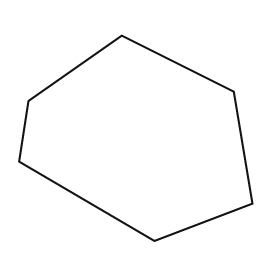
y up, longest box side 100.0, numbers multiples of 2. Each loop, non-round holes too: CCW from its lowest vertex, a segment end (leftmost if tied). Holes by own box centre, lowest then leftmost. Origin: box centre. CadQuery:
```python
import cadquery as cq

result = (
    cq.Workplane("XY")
    .moveTo(8.0, -44.0)
    .lineTo(50.0, -28.0)
    .lineTo(42.0, 20.0)
    .lineTo(-6.0, 44.0)
    .lineTo(-46.0, 16.0)
    .lineTo(-50.0, -10.0)
    .close()
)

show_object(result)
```